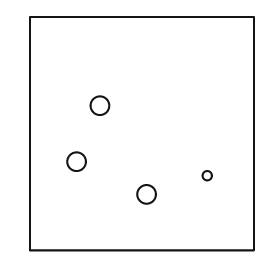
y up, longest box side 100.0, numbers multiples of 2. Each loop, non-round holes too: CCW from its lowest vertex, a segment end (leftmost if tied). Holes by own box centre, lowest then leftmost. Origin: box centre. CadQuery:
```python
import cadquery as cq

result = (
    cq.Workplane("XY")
    .moveTo(-48.0, -50.0)
    .lineTo(48.0, -50.0)
    .lineTo(48.0, 50.0)
    .lineTo(-48.0, 50.0)
    .close()
    .moveTo(2.0, -26.0)
    .circle(4.0)
    .moveTo(28.0, -18.0)
    .circle(2.0)
    .moveTo(-28.0, -12.0)
    .circle(4.0)
    .moveTo(-18.0, 12.0)
    .circle(4.0)
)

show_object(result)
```